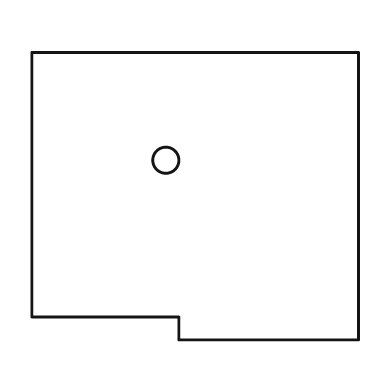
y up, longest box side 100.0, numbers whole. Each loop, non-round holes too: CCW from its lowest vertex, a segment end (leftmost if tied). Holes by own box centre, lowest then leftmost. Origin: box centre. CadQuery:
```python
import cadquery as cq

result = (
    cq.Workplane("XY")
    .moveTo(-5.0, -44.0)
    .lineTo(50.0, -44.0)
    .lineTo(50.0, 44.0)
    .lineTo(-50.0, 44.0)
    .lineTo(-50.0, -37.0)
    .lineTo(-5.0, -37.0)
    .close()
    .moveTo(-9.0, 11.0)
    .circle(4.0)
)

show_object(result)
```